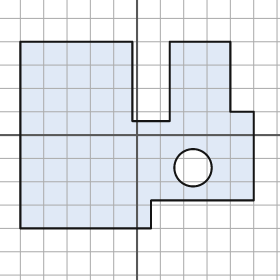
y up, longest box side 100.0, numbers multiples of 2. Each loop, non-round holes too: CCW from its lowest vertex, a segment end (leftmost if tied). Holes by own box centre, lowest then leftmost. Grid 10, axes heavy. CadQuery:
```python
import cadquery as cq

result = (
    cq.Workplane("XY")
    .moveTo(-50.0, -40.0)
    .lineTo(6.0, -40.0)
    .lineTo(6.0, -28.0)
    .lineTo(50.0, -28.0)
    .lineTo(50.0, 10.0)
    .lineTo(40.0, 10.0)
    .lineTo(40.0, 40.0)
    .lineTo(14.0, 40.0)
    .lineTo(14.0, 6.0)
    .lineTo(-2.0, 6.0)
    .lineTo(-2.0, 40.0)
    .lineTo(-50.0, 40.0)
    .close()
    .moveTo(24.0, -14.0)
    .circle(8.0)
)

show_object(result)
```